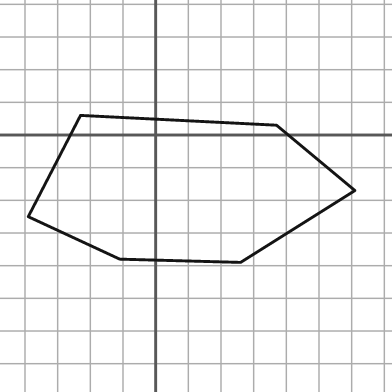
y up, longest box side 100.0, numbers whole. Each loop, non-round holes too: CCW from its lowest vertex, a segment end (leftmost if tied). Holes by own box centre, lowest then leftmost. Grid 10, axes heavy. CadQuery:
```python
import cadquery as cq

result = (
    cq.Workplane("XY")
    .moveTo(26.0, -39.0)
    .lineTo(61.0, -17.0)
    .lineTo(37.0, 3.0)
    .lineTo(-23.0, 6.0)
    .lineTo(-39.0, -25.0)
    .lineTo(-11.0, -38.0)
    .close()
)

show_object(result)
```